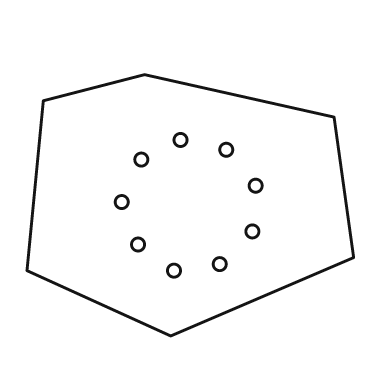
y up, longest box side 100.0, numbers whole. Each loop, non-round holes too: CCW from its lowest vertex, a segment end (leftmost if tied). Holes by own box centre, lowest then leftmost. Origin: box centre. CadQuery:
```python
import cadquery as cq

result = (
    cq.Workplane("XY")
    .moveTo(-6.0, -40.0)
    .lineTo(50.0, -16.0)
    .lineTo(44.0, 27.0)
    .lineTo(-14.0, 40.0)
    .lineTo(-45.0, 32.0)
    .lineTo(-50.0, -20.0)
    .close()
    .moveTo(-5.0, -20.0)
    .circle(2.0)
    .moveTo(9.0, -18.0)
    .circle(2.0)
    .moveTo(-16.0, -12.0)
    .circle(2.0)
    .moveTo(19.0, -8.0)
    .circle(2.0)
    .moveTo(-21.0, 1.0)
    .circle(2.0)
    .moveTo(20.0, 6.0)
    .circle(2.0)
    .moveTo(-15.0, 14.0)
    .circle(2.0)
    .moveTo(11.0, 17.0)
    .circle(2.0)
    .moveTo(-3.0, 20.0)
    .circle(2.0)
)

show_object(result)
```